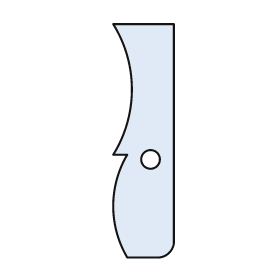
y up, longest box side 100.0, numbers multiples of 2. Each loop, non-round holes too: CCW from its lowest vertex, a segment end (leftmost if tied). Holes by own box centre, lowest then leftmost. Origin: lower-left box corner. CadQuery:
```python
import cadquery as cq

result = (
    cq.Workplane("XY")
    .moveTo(6.0, 0.0)
    .lineTo(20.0, 0.0)
    .threePointArc((24.0, 2.0), (26.0, 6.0))
    .lineTo(26.0, 100.0)
    .lineTo(0.0, 100.0)
    .threePointArc((8.0, 72.0), (0.0, 44.0))
    .lineTo(6.0, 44.0)
    .threePointArc((0.0, 22.0), (6.0, 0.0))
    .close()
    .moveTo(16.0, 42.0)
    .circle(4.0)
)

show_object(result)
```